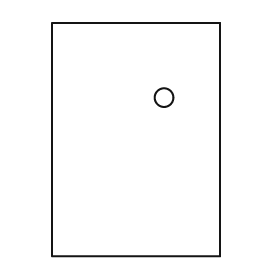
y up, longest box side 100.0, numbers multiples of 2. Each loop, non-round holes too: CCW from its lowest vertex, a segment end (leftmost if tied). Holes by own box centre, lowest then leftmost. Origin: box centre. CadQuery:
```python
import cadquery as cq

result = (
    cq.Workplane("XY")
    .moveTo(-36.0, -50.0)
    .lineTo(36.0, -50.0)
    .lineTo(36.0, 50.0)
    .lineTo(-36.0, 50.0)
    .close()
    .moveTo(12.0, 18.0)
    .circle(4.0)
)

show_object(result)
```